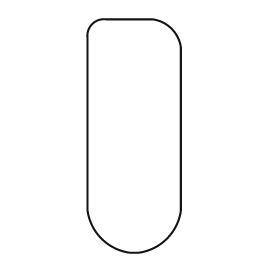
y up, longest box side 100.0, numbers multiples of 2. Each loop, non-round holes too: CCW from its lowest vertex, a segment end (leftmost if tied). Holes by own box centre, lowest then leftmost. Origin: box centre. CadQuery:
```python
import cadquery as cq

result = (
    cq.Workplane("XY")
    .moveTo(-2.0, -50.0)
    .lineTo(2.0, -50.0)
    .threePointArc((14.0, -44.0), (20.0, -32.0))
    .lineTo(20.0, 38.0)
    .threePointArc((16.0, 46.0), (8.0, 50.0))
    .lineTo(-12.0, 50.0)
    .threePointArc((-18.0, 48.0), (-20.0, 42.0))
    .lineTo(-20.0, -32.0)
    .threePointArc((-14.0, -44.0), (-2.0, -50.0))
    .close()
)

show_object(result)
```